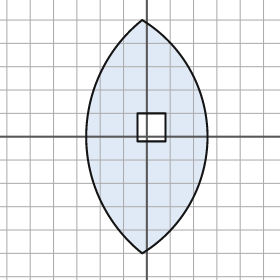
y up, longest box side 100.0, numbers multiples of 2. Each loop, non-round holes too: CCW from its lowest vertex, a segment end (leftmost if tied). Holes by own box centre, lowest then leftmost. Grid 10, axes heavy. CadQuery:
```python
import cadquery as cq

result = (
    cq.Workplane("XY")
    .moveTo(-2.0, -50.0)
    .threePointArc((26.0, 0.0), (-2.0, 50.0))
    .threePointArc((-26.0, 0.0), (-2.0, -50.0))
    .close()
    .moveTo(-4.0, -2.0)
    .lineTo(8.0, -2.0)
    .lineTo(8.0, 10.0)
    .lineTo(-4.0, 10.0)
    .close()
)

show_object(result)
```